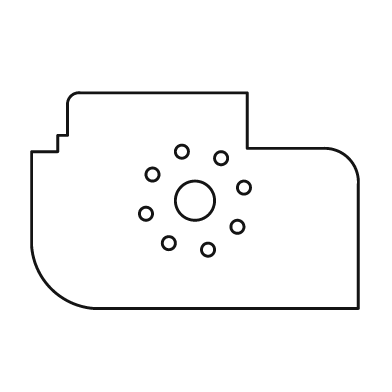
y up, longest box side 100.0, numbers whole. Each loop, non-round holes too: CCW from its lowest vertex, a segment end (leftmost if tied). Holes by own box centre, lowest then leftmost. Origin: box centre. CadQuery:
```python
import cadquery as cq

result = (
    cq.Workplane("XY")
    .moveTo(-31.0, -33.0)
    .lineTo(50.0, -33.0)
    .lineTo(50.0, 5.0)
    .threePointArc((47.0, 13.0), (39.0, 16.0))
    .lineTo(16.0, 16.0)
    .lineTo(16.0, 33.0)
    .lineTo(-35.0, 33.0)
    .threePointArc((-38.0, 32.0), (-39.0, 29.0))
    .lineTo(-39.0, 20.0)
    .lineTo(-42.0, 20.0)
    .lineTo(-42.0, 15.0)
    .lineTo(-50.0, 15.0)
    .lineTo(-50.0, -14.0)
    .threePointArc((-44.0, -27.0), (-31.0, -33.0))
    .close()
    .moveTo(4.0, -15.0)
    .circle(2.0)
    .moveTo(-8.0, -13.0)
    .circle(2.0)
    .moveTo(13.0, -8.0)
    .circle(2.0)
    .moveTo(-15.0, -4.0)
    .circle(2.0)
    .moveTo(0.0, 0.0)
    .circle(6.0)
    .moveTo(15.0, 4.0)
    .circle(2.0)
    .moveTo(-13.0, 8.0)
    .circle(2.0)
    .moveTo(8.0, 13.0)
    .circle(2.0)
    .moveTo(-4.0, 15.0)
    .circle(2.0)
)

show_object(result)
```